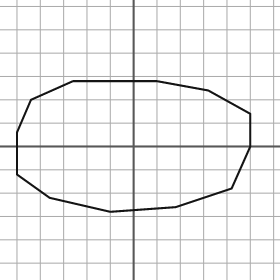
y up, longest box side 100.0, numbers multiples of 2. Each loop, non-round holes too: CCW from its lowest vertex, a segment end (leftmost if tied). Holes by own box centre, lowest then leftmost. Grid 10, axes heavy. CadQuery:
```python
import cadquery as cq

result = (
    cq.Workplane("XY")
    .moveTo(-10.0, -28.0)
    .lineTo(18.0, -26.0)
    .lineTo(42.0, -18.0)
    .lineTo(50.0, 0.0)
    .lineTo(50.0, 14.0)
    .lineTo(32.0, 24.0)
    .lineTo(10.0, 28.0)
    .lineTo(-26.0, 28.0)
    .lineTo(-44.0, 20.0)
    .lineTo(-50.0, 6.0)
    .lineTo(-50.0, -12.0)
    .lineTo(-36.0, -22.0)
    .close()
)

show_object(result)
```